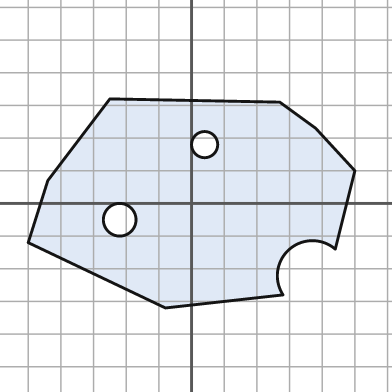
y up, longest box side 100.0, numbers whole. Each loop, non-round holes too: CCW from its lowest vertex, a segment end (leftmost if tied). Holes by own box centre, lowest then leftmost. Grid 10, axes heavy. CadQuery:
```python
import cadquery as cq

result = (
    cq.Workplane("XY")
    .moveTo(-8.0, -32.0)
    .lineTo(28.0, -28.0)
    .threePointArc((30.0, -14.0), (44.0, -14.0))
    .lineTo(50.0, 10.0)
    .lineTo(38.0, 23.0)
    .lineTo(27.0, 31.0)
    .lineTo(-25.0, 32.0)
    .lineTo(-44.0, 7.0)
    .lineTo(-50.0, -12.0)
    .close()
    .moveTo(-22.0, -5.0)
    .circle(5.0)
    .moveTo(4.0, 18.0)
    .circle(4.0)
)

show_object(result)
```